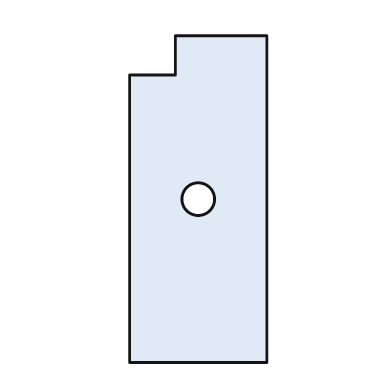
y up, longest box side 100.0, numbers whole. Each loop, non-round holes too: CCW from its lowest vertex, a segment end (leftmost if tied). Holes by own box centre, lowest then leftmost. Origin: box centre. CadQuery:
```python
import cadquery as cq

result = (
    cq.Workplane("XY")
    .moveTo(-21.0, -50.0)
    .lineTo(21.0, -50.0)
    .lineTo(21.0, 50.0)
    .lineTo(-7.0, 50.0)
    .lineTo(-7.0, 38.0)
    .lineTo(-21.0, 38.0)
    .close()
    .moveTo(0.0, 0.0)
    .circle(5.0)
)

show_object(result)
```